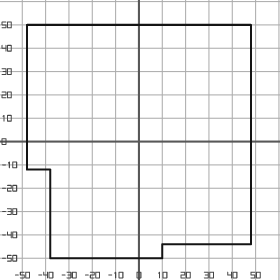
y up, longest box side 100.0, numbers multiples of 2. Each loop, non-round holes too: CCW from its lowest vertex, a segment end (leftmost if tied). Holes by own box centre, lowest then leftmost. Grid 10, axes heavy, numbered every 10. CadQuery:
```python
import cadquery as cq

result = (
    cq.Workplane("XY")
    .moveTo(-38.0, -50.0)
    .lineTo(10.0, -50.0)
    .lineTo(10.0, -44.0)
    .lineTo(48.0, -44.0)
    .lineTo(48.0, 50.0)
    .lineTo(-48.0, 50.0)
    .lineTo(-48.0, -12.0)
    .lineTo(-38.0, -12.0)
    .close()
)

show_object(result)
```